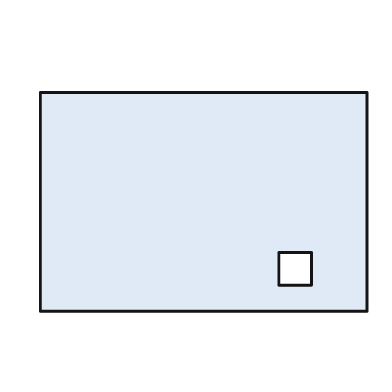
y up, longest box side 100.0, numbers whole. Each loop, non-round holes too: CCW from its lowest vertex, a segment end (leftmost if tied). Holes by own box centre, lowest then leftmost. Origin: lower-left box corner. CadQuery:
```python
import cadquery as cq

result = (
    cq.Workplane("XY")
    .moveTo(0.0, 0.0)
    .lineTo(100.0, 0.0)
    .lineTo(100.0, 67.0)
    .lineTo(0.0, 67.0)
    .close()
    .moveTo(73.0, 8.0)
    .lineTo(83.0, 8.0)
    .lineTo(83.0, 18.0)
    .lineTo(73.0, 18.0)
    .close()
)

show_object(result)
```